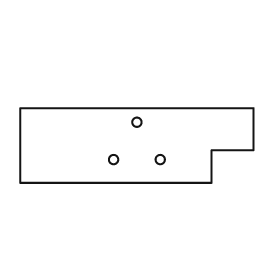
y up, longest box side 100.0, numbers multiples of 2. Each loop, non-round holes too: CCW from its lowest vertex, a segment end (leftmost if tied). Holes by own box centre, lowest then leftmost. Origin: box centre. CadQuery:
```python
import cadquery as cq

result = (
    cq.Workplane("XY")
    .moveTo(-50.0, -16.0)
    .lineTo(32.0, -16.0)
    .lineTo(32.0, -2.0)
    .lineTo(50.0, -2.0)
    .lineTo(50.0, 16.0)
    .lineTo(-50.0, 16.0)
    .close()
    .moveTo(-10.0, -6.0)
    .circle(2.0)
    .moveTo(10.0, -6.0)
    .circle(2.0)
    .moveTo(0.0, 10.0)
    .circle(2.0)
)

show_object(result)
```